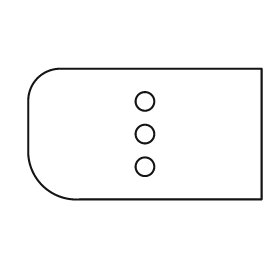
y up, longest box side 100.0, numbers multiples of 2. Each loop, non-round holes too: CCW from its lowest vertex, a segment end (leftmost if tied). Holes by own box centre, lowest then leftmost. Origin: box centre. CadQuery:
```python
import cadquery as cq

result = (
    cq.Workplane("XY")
    .moveTo(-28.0, -28.0)
    .lineTo(50.0, -28.0)
    .lineTo(50.0, 28.0)
    .lineTo(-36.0, 28.0)
    .threePointArc((-46.0, 24.0), (-50.0, 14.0))
    .lineTo(-50.0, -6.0)
    .threePointArc((-44.0, -22.0), (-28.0, -28.0))
    .close()
    .moveTo(0.0, -14.0)
    .circle(4.0)
    .moveTo(0.0, 0.0)
    .circle(4.0)
    .moveTo(0.0, 14.0)
    .circle(4.0)
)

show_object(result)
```